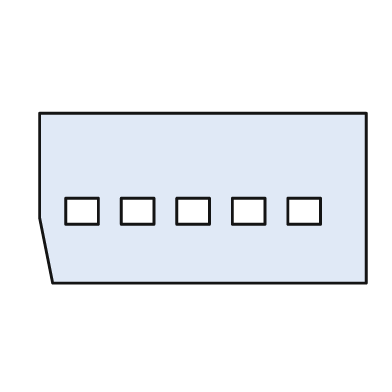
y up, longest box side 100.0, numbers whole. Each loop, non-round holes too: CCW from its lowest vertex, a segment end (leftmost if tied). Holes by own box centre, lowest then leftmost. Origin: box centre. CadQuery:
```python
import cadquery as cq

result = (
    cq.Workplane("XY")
    .moveTo(-46.0, -26.0)
    .lineTo(50.0, -26.0)
    .lineTo(50.0, 26.0)
    .lineTo(-50.0, 26.0)
    .lineTo(-50.0, -6.0)
    .close()
    .moveTo(-42.0, -8.0)
    .lineTo(-32.0, -8.0)
    .lineTo(-32.0, 0.0)
    .lineTo(-42.0, 0.0)
    .close()
    .moveTo(-25.0, -8.0)
    .lineTo(-15.0, -8.0)
    .lineTo(-15.0, 0.0)
    .lineTo(-25.0, 0.0)
    .close()
    .moveTo(-8.0, -8.0)
    .lineTo(2.0, -8.0)
    .lineTo(2.0, 0.0)
    .lineTo(-8.0, 0.0)
    .close()
    .moveTo(9.0, -8.0)
    .lineTo(19.0, -8.0)
    .lineTo(19.0, 0.0)
    .lineTo(9.0, 0.0)
    .close()
    .moveTo(26.0, -8.0)
    .lineTo(36.0, -8.0)
    .lineTo(36.0, 0.0)
    .lineTo(26.0, 0.0)
    .close()
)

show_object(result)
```